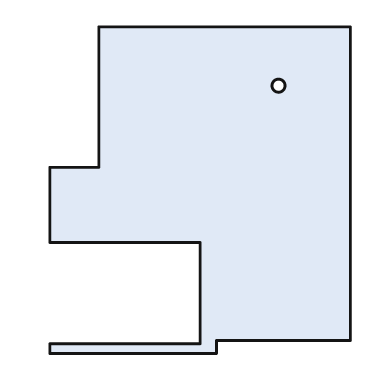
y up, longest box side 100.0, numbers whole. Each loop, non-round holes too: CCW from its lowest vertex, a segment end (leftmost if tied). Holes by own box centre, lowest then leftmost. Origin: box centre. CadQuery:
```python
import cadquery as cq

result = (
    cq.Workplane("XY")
    .moveTo(-46.0, -50.0)
    .lineTo(5.0, -50.0)
    .lineTo(5.0, -46.0)
    .lineTo(46.0, -46.0)
    .lineTo(46.0, 50.0)
    .lineTo(-31.0, 50.0)
    .lineTo(-31.0, 7.0)
    .lineTo(-46.0, 7.0)
    .lineTo(-46.0, -16.0)
    .lineTo(0.0, -16.0)
    .lineTo(0.0, -47.0)
    .lineTo(-46.0, -47.0)
    .close()
    .moveTo(24.0, 32.0)
    .circle(2.0)
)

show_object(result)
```